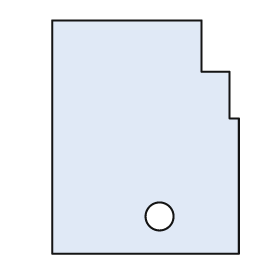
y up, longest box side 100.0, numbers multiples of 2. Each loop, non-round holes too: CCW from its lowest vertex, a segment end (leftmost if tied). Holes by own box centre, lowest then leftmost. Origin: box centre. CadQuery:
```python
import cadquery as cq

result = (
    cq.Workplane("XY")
    .moveTo(-40.0, -50.0)
    .lineTo(40.0, -50.0)
    .lineTo(40.0, 8.0)
    .lineTo(36.0, 8.0)
    .lineTo(36.0, 28.0)
    .lineTo(24.0, 28.0)
    .lineTo(24.0, 50.0)
    .lineTo(-40.0, 50.0)
    .close()
    .moveTo(6.0, -34.0)
    .circle(6.0)
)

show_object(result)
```